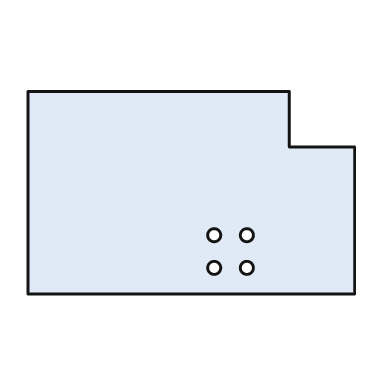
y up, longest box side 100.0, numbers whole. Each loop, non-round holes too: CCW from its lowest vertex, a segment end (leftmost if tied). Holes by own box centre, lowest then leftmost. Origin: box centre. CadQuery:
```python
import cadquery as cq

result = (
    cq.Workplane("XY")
    .moveTo(-50.0, -31.0)
    .lineTo(50.0, -31.0)
    .lineTo(50.0, 14.0)
    .lineTo(30.0, 14.0)
    .lineTo(30.0, 31.0)
    .lineTo(-50.0, 31.0)
    .close()
    .moveTo(7.0, -23.0)
    .circle(2.0)
    .moveTo(17.0, -23.0)
    .circle(2.0)
    .moveTo(7.0, -13.0)
    .circle(2.0)
    .moveTo(17.0, -13.0)
    .circle(2.0)
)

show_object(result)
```